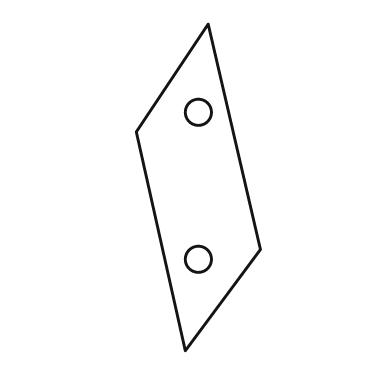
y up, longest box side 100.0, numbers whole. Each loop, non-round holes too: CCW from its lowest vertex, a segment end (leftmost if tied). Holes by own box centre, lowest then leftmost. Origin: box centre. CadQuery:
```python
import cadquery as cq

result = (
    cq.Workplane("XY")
    .moveTo(-4.0, -50.0)
    .lineTo(19.0, -19.0)
    .lineTo(3.0, 50.0)
    .lineTo(-19.0, 17.0)
    .close()
    .moveTo(0.0, -22.0)
    .circle(4.0)
    .moveTo(0.0, 23.0)
    .circle(4.0)
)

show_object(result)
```